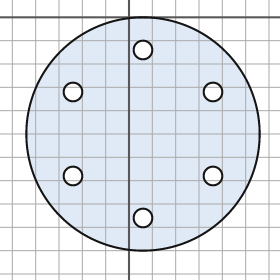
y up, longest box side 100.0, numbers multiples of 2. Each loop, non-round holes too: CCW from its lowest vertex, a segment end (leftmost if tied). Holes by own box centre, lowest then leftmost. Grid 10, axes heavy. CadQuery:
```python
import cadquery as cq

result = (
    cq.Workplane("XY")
    .moveTo(6.0, -50.0)
    .circle(50.0)
    .moveTo(6.0, -86.0)
    .circle(4.0)
    .moveTo(-24.0, -68.0)
    .circle(4.0)
    .moveTo(36.0, -68.0)
    .circle(4.0)
    .moveTo(-24.0, -32.0)
    .circle(4.0)
    .moveTo(36.0, -32.0)
    .circle(4.0)
    .moveTo(6.0, -14.0)
    .circle(4.0)
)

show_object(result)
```